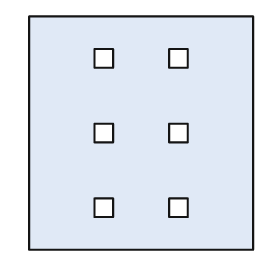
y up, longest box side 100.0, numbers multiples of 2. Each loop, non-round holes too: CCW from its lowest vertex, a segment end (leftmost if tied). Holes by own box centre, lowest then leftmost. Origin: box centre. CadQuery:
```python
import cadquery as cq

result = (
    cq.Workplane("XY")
    .moveTo(-48.0, -50.0)
    .lineTo(48.0, -50.0)
    .lineTo(48.0, 50.0)
    .lineTo(-48.0, 50.0)
    .close()
    .moveTo(-20.0, -36.0)
    .lineTo(-12.0, -36.0)
    .lineTo(-12.0, -28.0)
    .lineTo(-20.0, -28.0)
    .close()
    .moveTo(12.0, -36.0)
    .lineTo(20.0, -36.0)
    .lineTo(20.0, -28.0)
    .lineTo(12.0, -28.0)
    .close()
    .moveTo(-20.0, -4.0)
    .lineTo(-12.0, -4.0)
    .lineTo(-12.0, 4.0)
    .lineTo(-20.0, 4.0)
    .close()
    .moveTo(12.0, -4.0)
    .lineTo(20.0, -4.0)
    .lineTo(20.0, 4.0)
    .lineTo(12.0, 4.0)
    .close()
    .moveTo(-20.0, 28.0)
    .lineTo(-12.0, 28.0)
    .lineTo(-12.0, 36.0)
    .lineTo(-20.0, 36.0)
    .close()
    .moveTo(12.0, 28.0)
    .lineTo(20.0, 28.0)
    .lineTo(20.0, 36.0)
    .lineTo(12.0, 36.0)
    .close()
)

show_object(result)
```